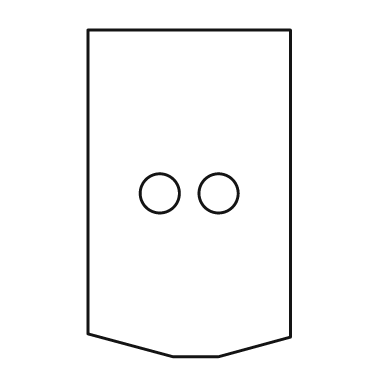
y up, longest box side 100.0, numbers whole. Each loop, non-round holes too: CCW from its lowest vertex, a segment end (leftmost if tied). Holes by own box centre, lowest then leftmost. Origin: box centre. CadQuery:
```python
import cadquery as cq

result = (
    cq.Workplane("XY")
    .moveTo(-5.0, -50.0)
    .lineTo(9.0, -50.0)
    .lineTo(31.0, -44.0)
    .lineTo(31.0, 50.0)
    .lineTo(-31.0, 50.0)
    .lineTo(-31.0, -43.0)
    .close()
    .moveTo(-9.0, 0.0)
    .circle(6.0)
    .moveTo(9.0, 0.0)
    .circle(6.0)
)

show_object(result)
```